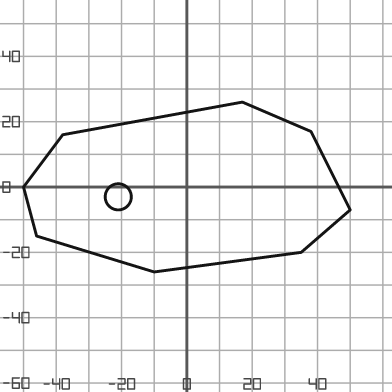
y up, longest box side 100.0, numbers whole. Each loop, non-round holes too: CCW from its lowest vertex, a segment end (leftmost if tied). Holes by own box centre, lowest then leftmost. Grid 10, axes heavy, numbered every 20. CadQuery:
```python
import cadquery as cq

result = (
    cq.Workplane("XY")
    .moveTo(-10.0, -26.0)
    .lineTo(35.0, -20.0)
    .lineTo(50.0, -7.0)
    .lineTo(38.0, 17.0)
    .lineTo(17.0, 26.0)
    .lineTo(-38.0, 16.0)
    .lineTo(-50.0, 0.0)
    .lineTo(-46.0, -15.0)
    .close()
    .moveTo(-21.0, -3.0)
    .circle(4.0)
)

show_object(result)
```